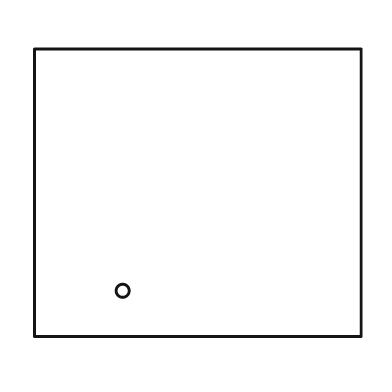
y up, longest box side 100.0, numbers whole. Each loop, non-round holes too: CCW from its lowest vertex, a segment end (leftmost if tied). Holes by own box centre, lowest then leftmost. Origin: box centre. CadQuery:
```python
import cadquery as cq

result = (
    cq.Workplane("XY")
    .moveTo(-50.0, -44.0)
    .lineTo(50.0, -44.0)
    .lineTo(50.0, 44.0)
    .lineTo(-50.0, 44.0)
    .close()
    .moveTo(-23.0, -30.0)
    .circle(2.0)
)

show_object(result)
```